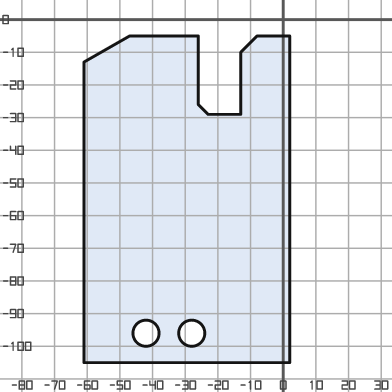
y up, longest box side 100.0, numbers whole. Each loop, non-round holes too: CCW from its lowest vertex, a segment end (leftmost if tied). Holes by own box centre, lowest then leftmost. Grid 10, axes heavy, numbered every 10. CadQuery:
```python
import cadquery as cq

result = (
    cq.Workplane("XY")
    .moveTo(-61.0, -105.0)
    .lineTo(2.0, -105.0)
    .lineTo(2.0, -5.0)
    .lineTo(-8.0, -5.0)
    .lineTo(-13.0, -10.0)
    .lineTo(-13.0, -29.0)
    .lineTo(-23.0, -29.0)
    .lineTo(-26.0, -26.0)
    .lineTo(-26.0, -5.0)
    .lineTo(-47.0, -5.0)
    .lineTo(-61.0, -13.0)
    .close()
    .moveTo(-42.0, -96.0)
    .circle(4.0)
    .moveTo(-28.0, -96.0)
    .circle(4.0)
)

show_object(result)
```